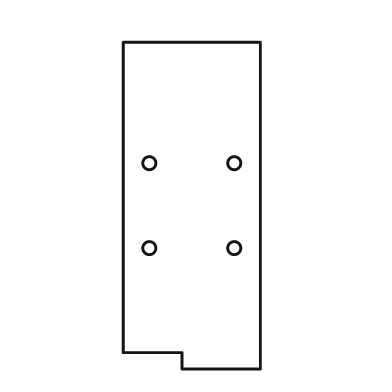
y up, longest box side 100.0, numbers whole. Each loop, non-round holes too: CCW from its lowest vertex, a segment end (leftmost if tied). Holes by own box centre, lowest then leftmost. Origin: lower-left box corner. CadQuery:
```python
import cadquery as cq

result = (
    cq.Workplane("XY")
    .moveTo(18.0, 0.0)
    .lineTo(42.0, 0.0)
    .lineTo(42.0, 100.0)
    .lineTo(0.0, 100.0)
    .lineTo(0.0, 5.0)
    .lineTo(18.0, 5.0)
    .close()
    .moveTo(8.0, 37.0)
    .circle(2.0)
    .moveTo(34.0, 37.0)
    .circle(2.0)
    .moveTo(8.0, 63.0)
    .circle(2.0)
    .moveTo(34.0, 63.0)
    .circle(2.0)
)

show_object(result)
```